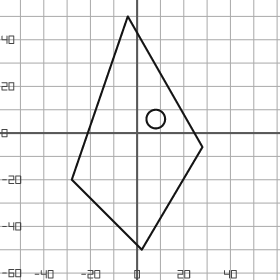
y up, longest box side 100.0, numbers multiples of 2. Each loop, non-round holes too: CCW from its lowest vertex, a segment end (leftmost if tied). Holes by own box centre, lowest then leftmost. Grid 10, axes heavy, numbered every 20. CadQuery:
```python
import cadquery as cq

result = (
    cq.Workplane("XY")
    .moveTo(2.0, -50.0)
    .lineTo(28.0, -6.0)
    .lineTo(-4.0, 50.0)
    .lineTo(-28.0, -20.0)
    .close()
    .moveTo(8.0, 6.0)
    .circle(4.0)
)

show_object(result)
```